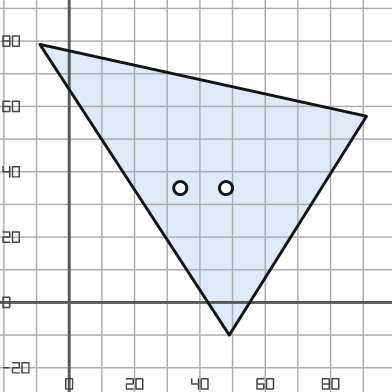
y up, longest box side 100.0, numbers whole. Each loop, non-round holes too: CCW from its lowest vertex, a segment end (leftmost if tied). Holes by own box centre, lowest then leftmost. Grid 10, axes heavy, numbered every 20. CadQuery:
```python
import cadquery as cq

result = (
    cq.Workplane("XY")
    .moveTo(49.0, -10.0)
    .lineTo(91.0, 57.0)
    .lineTo(-9.0, 79.0)
    .close()
    .moveTo(34.0, 35.0)
    .circle(2.0)
    .moveTo(48.0, 35.0)
    .circle(2.0)
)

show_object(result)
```